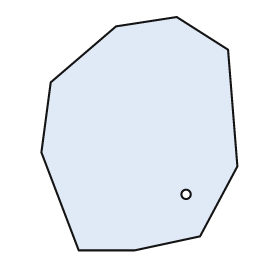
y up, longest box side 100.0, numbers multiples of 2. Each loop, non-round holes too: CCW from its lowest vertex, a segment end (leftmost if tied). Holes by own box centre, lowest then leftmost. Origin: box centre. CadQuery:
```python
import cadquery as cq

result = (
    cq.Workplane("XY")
    .moveTo(-26.0, -50.0)
    .lineTo(-2.0, -50.0)
    .lineTo(26.0, -44.0)
    .lineTo(42.0, -14.0)
    .lineTo(38.0, 36.0)
    .lineTo(16.0, 50.0)
    .lineTo(-10.0, 46.0)
    .lineTo(-38.0, 22.0)
    .lineTo(-42.0, -8.0)
    .close()
    .moveTo(20.0, -26.0)
    .circle(2.0)
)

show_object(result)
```